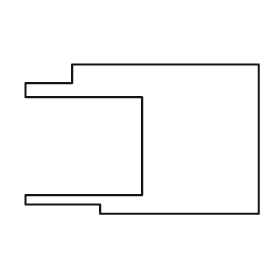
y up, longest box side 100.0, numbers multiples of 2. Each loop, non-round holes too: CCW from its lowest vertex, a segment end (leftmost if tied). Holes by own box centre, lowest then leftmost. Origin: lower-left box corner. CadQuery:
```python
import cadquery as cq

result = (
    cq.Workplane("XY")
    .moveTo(32.0, 0.0)
    .lineTo(100.0, 0.0)
    .lineTo(100.0, 64.0)
    .lineTo(20.0, 64.0)
    .lineTo(20.0, 56.0)
    .lineTo(0.0, 56.0)
    .lineTo(0.0, 50.0)
    .lineTo(50.0, 50.0)
    .lineTo(50.0, 8.0)
    .lineTo(0.0, 8.0)
    .lineTo(0.0, 4.0)
    .lineTo(32.0, 4.0)
    .close()
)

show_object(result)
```